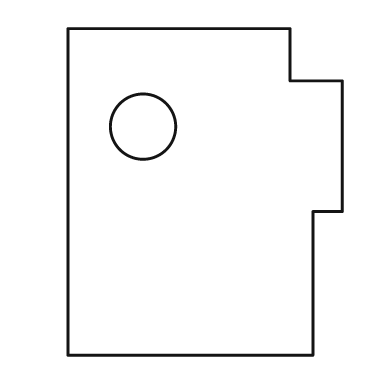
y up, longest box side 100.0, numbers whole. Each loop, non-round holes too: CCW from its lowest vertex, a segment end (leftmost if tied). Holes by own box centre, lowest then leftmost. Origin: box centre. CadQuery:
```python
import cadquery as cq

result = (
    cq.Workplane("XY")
    .moveTo(-42.0, -50.0)
    .lineTo(33.0, -50.0)
    .lineTo(33.0, -6.0)
    .lineTo(42.0, -6.0)
    .lineTo(42.0, 34.0)
    .lineTo(26.0, 34.0)
    .lineTo(26.0, 50.0)
    .lineTo(-42.0, 50.0)
    .close()
    .moveTo(-19.0, 20.0)
    .circle(10.0)
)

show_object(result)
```